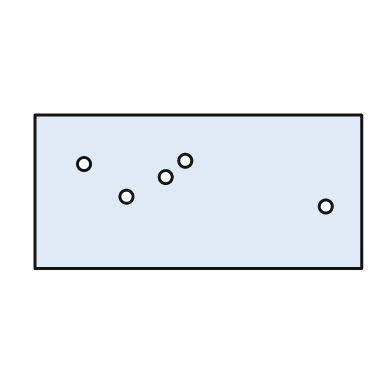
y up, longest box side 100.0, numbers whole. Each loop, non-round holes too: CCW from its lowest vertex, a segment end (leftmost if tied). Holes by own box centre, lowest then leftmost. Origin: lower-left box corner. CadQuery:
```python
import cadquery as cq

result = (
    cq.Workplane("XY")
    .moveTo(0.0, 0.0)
    .lineTo(100.0, 0.0)
    .lineTo(100.0, 47.0)
    .lineTo(0.0, 47.0)
    .close()
    .moveTo(89.0, 19.0)
    .circle(2.0)
    .moveTo(28.0, 22.0)
    .circle(2.0)
    .moveTo(40.0, 28.0)
    .circle(2.0)
    .moveTo(15.0, 32.0)
    .circle(2.0)
    .moveTo(46.0, 33.0)
    .circle(2.0)
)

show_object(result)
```